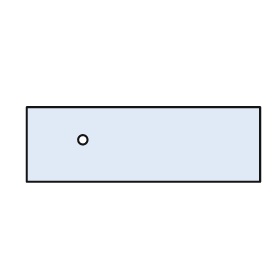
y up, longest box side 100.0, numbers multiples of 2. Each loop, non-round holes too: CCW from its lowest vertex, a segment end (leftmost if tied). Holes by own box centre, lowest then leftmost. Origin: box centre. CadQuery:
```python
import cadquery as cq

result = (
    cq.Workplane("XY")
    .moveTo(-50.0, -16.0)
    .lineTo(50.0, -16.0)
    .lineTo(50.0, 16.0)
    .lineTo(-50.0, 16.0)
    .close()
    .moveTo(-26.0, 2.0)
    .circle(2.0)
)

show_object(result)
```